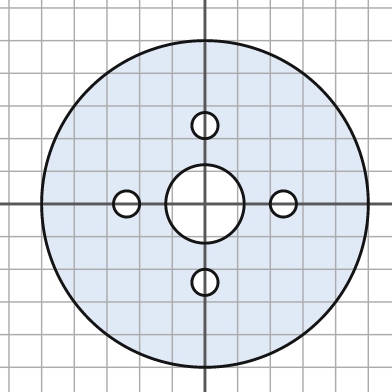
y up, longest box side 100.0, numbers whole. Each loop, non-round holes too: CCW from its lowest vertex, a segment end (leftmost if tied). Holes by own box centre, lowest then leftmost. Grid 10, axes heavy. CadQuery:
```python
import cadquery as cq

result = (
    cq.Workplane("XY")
    .moveTo(0.0, 0.0)
    .circle(50.0)
    .moveTo(0.0, -24.0)
    .circle(4.0)
    .moveTo(-24.0, 0.0)
    .circle(4.0)
    .moveTo(0.0, 0.0)
    .circle(12.0)
    .moveTo(24.0, 0.0)
    .circle(4.0)
    .moveTo(0.0, 24.0)
    .circle(4.0)
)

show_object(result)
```